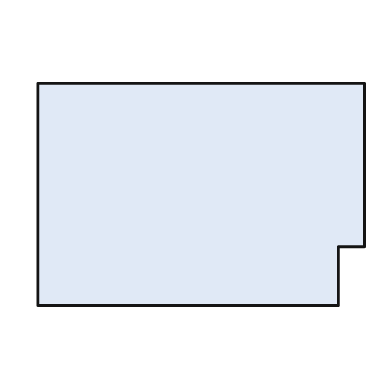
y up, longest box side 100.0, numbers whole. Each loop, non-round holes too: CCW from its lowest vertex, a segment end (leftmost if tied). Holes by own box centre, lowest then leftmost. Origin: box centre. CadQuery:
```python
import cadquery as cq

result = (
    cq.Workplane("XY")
    .moveTo(-50.0, -34.0)
    .lineTo(42.0, -34.0)
    .lineTo(42.0, -16.0)
    .lineTo(50.0, -16.0)
    .lineTo(50.0, 34.0)
    .lineTo(-50.0, 34.0)
    .close()
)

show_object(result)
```